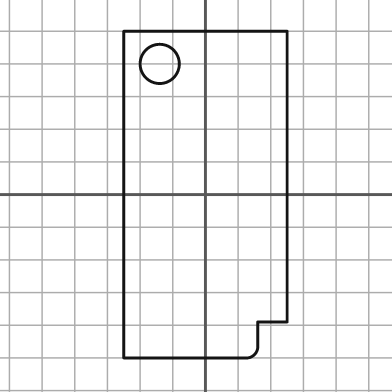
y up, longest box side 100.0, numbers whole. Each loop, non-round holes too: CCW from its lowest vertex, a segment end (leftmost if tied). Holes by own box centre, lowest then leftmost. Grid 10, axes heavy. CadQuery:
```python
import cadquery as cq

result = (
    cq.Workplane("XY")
    .moveTo(-25.0, -50.0)
    .lineTo(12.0, -50.0)
    .threePointArc((15.0, -49.0), (16.0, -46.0))
    .lineTo(16.0, -39.0)
    .lineTo(25.0, -39.0)
    .lineTo(25.0, 50.0)
    .lineTo(-25.0, 50.0)
    .close()
    .moveTo(-14.0, 40.0)
    .circle(6.0)
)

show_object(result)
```